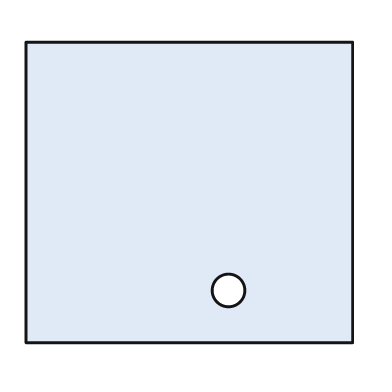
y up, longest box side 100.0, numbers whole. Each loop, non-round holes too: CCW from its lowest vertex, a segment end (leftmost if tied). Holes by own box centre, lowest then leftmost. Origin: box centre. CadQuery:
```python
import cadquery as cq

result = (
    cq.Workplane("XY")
    .moveTo(-50.0, -46.0)
    .lineTo(50.0, -46.0)
    .lineTo(50.0, 46.0)
    .lineTo(-50.0, 46.0)
    .close()
    .moveTo(12.0, -30.0)
    .circle(5.0)
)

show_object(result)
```